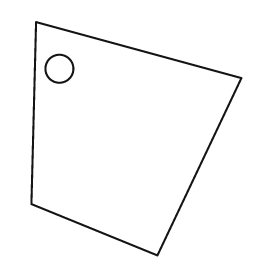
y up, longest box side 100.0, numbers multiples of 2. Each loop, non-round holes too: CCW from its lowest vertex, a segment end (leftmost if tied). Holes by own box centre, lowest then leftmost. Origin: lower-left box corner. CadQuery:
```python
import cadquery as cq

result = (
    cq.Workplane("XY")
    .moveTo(54.0, 0.0)
    .lineTo(90.0, 76.0)
    .lineTo(2.0, 100.0)
    .lineTo(0.0, 22.0)
    .close()
    .moveTo(12.0, 80.0)
    .circle(6.0)
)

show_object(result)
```